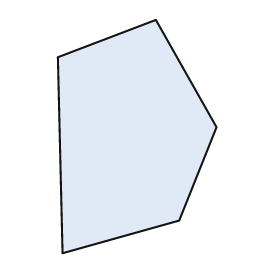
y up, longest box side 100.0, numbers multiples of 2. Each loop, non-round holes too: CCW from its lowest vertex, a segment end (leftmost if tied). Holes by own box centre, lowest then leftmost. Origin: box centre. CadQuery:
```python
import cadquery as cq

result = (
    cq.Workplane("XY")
    .moveTo(-32.0, -50.0)
    .lineTo(18.0, -36.0)
    .lineTo(34.0, 4.0)
    .lineTo(8.0, 50.0)
    .lineTo(-34.0, 34.0)
    .close()
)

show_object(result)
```